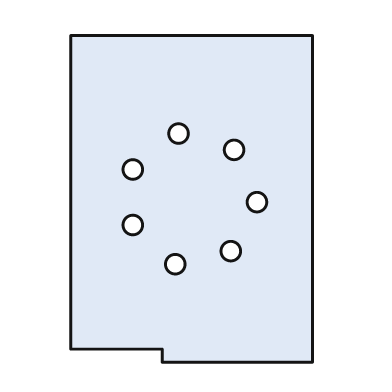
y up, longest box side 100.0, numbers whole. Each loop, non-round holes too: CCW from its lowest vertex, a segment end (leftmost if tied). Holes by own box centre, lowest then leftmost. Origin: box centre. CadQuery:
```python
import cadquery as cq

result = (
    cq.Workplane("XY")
    .moveTo(-9.0, -50.0)
    .lineTo(37.0, -50.0)
    .lineTo(37.0, 50.0)
    .lineTo(-37.0, 50.0)
    .lineTo(-37.0, -46.0)
    .lineTo(-9.0, -46.0)
    .close()
    .moveTo(-5.0, -20.0)
    .circle(3.0)
    .moveTo(12.0, -16.0)
    .circle(3.0)
    .moveTo(-18.0, -8.0)
    .circle(3.0)
    .moveTo(20.0, -1.0)
    .circle(3.0)
    .moveTo(-18.0, 9.0)
    .circle(3.0)
    .moveTo(13.0, 15.0)
    .circle(3.0)
    .moveTo(-4.0, 20.0)
    .circle(3.0)
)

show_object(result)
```